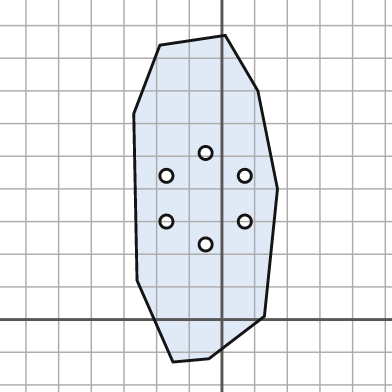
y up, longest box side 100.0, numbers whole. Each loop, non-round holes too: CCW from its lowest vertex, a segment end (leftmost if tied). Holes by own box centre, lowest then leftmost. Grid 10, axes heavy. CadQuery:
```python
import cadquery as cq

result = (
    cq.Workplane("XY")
    .moveTo(-15.0, -13.0)
    .lineTo(-4.0, -12.0)
    .lineTo(13.0, 1.0)
    .lineTo(17.0, 40.0)
    .lineTo(11.0, 70.0)
    .lineTo(1.0, 87.0)
    .lineTo(-19.0, 84.0)
    .lineTo(-27.0, 63.0)
    .lineTo(-26.0, 12.0)
    .close()
    .moveTo(-5.0, 23.0)
    .circle(2.0)
    .moveTo(-17.0, 30.0)
    .circle(2.0)
    .moveTo(7.0, 30.0)
    .circle(2.0)
    .moveTo(-17.0, 44.0)
    .circle(2.0)
    .moveTo(7.0, 44.0)
    .circle(2.0)
    .moveTo(-5.0, 51.0)
    .circle(2.0)
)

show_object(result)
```